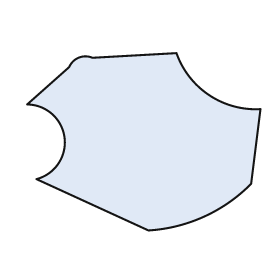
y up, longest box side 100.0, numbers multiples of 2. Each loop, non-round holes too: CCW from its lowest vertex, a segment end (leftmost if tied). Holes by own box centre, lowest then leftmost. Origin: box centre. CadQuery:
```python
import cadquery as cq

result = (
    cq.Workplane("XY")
    .moveTo(2.0, -38.0)
    .threePointArc((26.0, -32.0), (46.0, -18.0))
    .lineTo(50.0, 14.0)
    .threePointArc((28.0, 20.0), (14.0, 38.0))
    .lineTo(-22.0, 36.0)
    .threePointArc((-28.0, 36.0), (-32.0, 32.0))
    .lineTo(-50.0, 16.0)
    .threePointArc((-34.0, 2.0), (-46.0, -16.0))
    .close()
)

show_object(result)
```